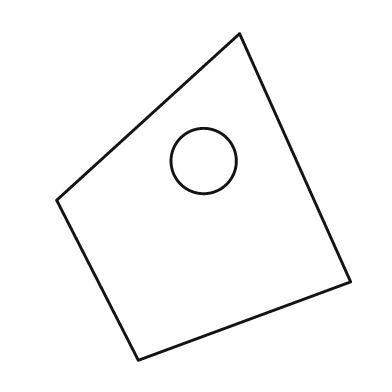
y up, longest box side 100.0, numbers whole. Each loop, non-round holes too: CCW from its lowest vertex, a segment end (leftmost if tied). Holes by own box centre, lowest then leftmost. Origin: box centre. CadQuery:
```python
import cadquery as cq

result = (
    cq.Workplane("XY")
    .moveTo(-20.0, -50.0)
    .lineTo(45.0, -26.0)
    .lineTo(11.0, 50.0)
    .lineTo(-45.0, -1.0)
    .close()
    .moveTo(0.0, 11.0)
    .circle(10.0)
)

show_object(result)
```